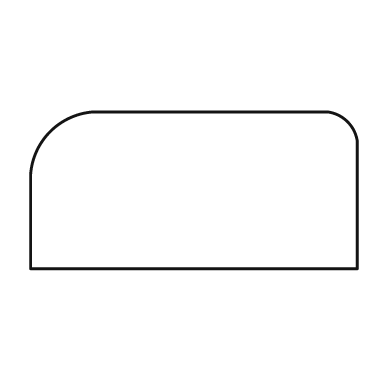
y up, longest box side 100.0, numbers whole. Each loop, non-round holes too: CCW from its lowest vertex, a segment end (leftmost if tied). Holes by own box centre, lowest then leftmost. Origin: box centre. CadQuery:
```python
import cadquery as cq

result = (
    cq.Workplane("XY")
    .moveTo(-50.0, -24.0)
    .lineTo(50.0, -24.0)
    .lineTo(50.0, 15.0)
    .threePointArc((47.0, 21.0), (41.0, 24.0))
    .lineTo(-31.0, 24.0)
    .threePointArc((-44.0, 18.0), (-50.0, 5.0))
    .close()
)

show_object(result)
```